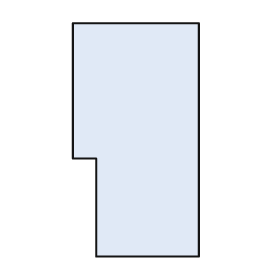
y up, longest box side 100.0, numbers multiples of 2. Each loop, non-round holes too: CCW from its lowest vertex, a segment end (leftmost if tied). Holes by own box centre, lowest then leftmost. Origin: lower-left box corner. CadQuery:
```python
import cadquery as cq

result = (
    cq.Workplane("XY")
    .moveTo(10.0, 0.0)
    .lineTo(54.0, 0.0)
    .lineTo(54.0, 100.0)
    .lineTo(0.0, 100.0)
    .lineTo(0.0, 42.0)
    .lineTo(10.0, 42.0)
    .close()
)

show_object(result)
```